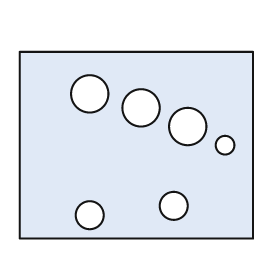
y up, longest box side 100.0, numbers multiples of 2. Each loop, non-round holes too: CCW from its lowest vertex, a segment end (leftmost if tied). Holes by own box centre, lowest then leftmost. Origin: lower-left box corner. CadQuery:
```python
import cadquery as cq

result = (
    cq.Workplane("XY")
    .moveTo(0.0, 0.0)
    .lineTo(100.0, 0.0)
    .lineTo(100.0, 80.0)
    .lineTo(0.0, 80.0)
    .close()
    .moveTo(30.0, 10.0)
    .circle(6.0)
    .moveTo(66.0, 14.0)
    .circle(6.0)
    .moveTo(88.0, 40.0)
    .circle(4.0)
    .moveTo(72.0, 48.0)
    .circle(8.0)
    .moveTo(52.0, 56.0)
    .circle(8.0)
    .moveTo(30.0, 62.0)
    .circle(8.0)
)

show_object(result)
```